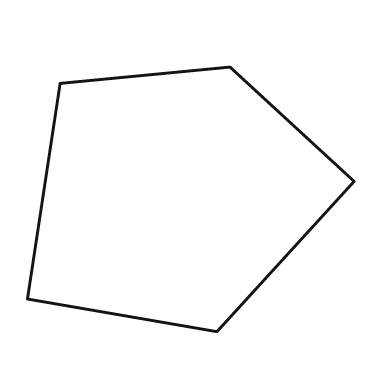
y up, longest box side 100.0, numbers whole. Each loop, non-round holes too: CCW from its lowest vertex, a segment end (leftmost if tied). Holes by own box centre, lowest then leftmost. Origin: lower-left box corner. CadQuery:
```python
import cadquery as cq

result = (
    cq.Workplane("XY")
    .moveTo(58.0, 0.0)
    .lineTo(100.0, 46.0)
    .lineTo(62.0, 81.0)
    .lineTo(10.0, 76.0)
    .lineTo(0.0, 10.0)
    .close()
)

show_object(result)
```